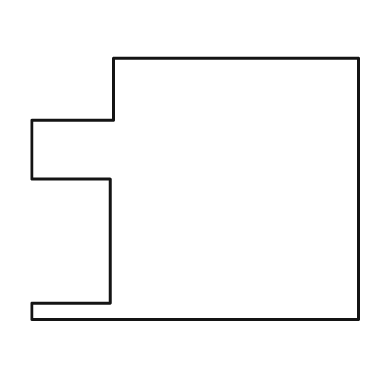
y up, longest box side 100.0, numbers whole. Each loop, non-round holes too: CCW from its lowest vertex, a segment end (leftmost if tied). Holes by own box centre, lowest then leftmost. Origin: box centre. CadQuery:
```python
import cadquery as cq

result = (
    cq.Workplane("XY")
    .moveTo(-50.0, -40.0)
    .lineTo(50.0, -40.0)
    .lineTo(50.0, 40.0)
    .lineTo(-25.0, 40.0)
    .lineTo(-25.0, 21.0)
    .lineTo(-50.0, 21.0)
    .lineTo(-50.0, 3.0)
    .lineTo(-26.0, 3.0)
    .lineTo(-26.0, -35.0)
    .lineTo(-50.0, -35.0)
    .close()
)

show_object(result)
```